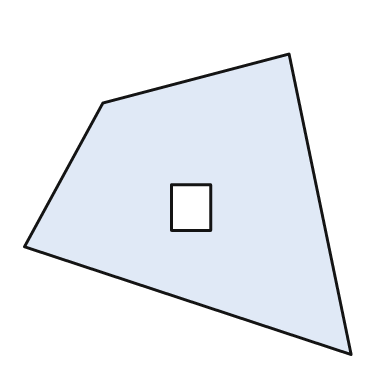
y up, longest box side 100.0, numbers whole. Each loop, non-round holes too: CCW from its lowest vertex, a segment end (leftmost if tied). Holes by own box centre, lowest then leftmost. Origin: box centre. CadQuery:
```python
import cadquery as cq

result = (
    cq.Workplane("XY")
    .moveTo(50.0, -46.0)
    .lineTo(31.0, 46.0)
    .lineTo(-26.0, 31.0)
    .lineTo(-50.0, -13.0)
    .close()
    .moveTo(-5.0, -8.0)
    .lineTo(7.0, -8.0)
    .lineTo(7.0, 6.0)
    .lineTo(-5.0, 6.0)
    .close()
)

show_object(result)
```